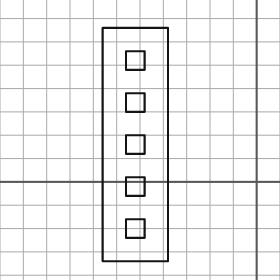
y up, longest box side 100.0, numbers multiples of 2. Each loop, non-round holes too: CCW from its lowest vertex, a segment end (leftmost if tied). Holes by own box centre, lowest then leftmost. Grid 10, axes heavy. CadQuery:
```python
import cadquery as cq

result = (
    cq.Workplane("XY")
    .moveTo(-66.0, -34.0)
    .lineTo(-38.0, -34.0)
    .lineTo(-38.0, 66.0)
    .lineTo(-66.0, 66.0)
    .close()
    .moveTo(-56.0, -24.0)
    .lineTo(-48.0, -24.0)
    .lineTo(-48.0, -16.0)
    .lineTo(-56.0, -16.0)
    .close()
    .moveTo(-56.0, -6.0)
    .lineTo(-48.0, -6.0)
    .lineTo(-48.0, 2.0)
    .lineTo(-56.0, 2.0)
    .close()
    .moveTo(-56.0, 12.0)
    .lineTo(-48.0, 12.0)
    .lineTo(-48.0, 20.0)
    .lineTo(-56.0, 20.0)
    .close()
    .moveTo(-56.0, 30.0)
    .lineTo(-48.0, 30.0)
    .lineTo(-48.0, 38.0)
    .lineTo(-56.0, 38.0)
    .close()
    .moveTo(-56.0, 48.0)
    .lineTo(-48.0, 48.0)
    .lineTo(-48.0, 56.0)
    .lineTo(-56.0, 56.0)
    .close()
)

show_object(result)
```